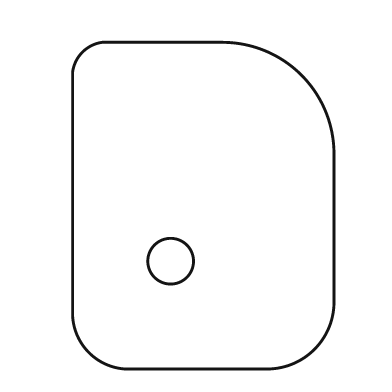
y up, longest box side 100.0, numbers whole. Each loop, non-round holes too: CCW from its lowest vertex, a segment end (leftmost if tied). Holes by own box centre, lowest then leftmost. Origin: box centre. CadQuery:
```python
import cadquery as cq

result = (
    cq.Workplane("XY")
    .moveTo(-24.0, -50.0)
    .lineTo(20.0, -50.0)
    .threePointArc((34.0, -44.0), (40.0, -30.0))
    .lineTo(40.0, 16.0)
    .threePointArc((30.0, 40.0), (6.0, 50.0))
    .lineTo(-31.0, 50.0)
    .threePointArc((-37.0, 47.0), (-40.0, 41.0))
    .lineTo(-40.0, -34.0)
    .threePointArc((-35.0, -45.0), (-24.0, -50.0))
    .close()
    .moveTo(-10.0, -17.0)
    .circle(7.0)
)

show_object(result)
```